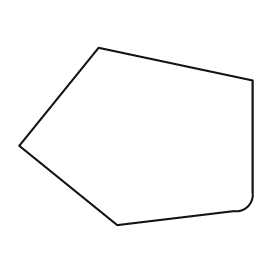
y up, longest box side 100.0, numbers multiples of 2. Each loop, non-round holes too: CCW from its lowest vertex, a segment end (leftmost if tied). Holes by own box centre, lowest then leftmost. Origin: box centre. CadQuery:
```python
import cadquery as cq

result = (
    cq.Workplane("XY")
    .moveTo(-8.0, -38.0)
    .lineTo(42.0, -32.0)
    .threePointArc((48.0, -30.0), (50.0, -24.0))
    .lineTo(50.0, 24.0)
    .lineTo(-16.0, 38.0)
    .lineTo(-50.0, -4.0)
    .close()
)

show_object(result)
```